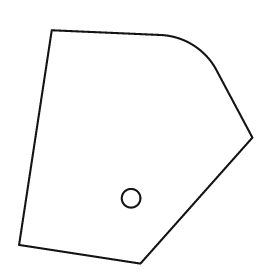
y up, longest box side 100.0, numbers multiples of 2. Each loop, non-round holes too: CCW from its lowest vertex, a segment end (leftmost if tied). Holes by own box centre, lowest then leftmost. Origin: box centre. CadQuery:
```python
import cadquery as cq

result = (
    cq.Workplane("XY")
    .moveTo(2.0, -50.0)
    .lineTo(50.0, 4.0)
    .lineTo(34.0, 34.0)
    .threePointArc((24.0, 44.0), (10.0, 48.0))
    .lineTo(-36.0, 50.0)
    .lineTo(-50.0, -42.0)
    .close()
    .moveTo(-2.0, -22.0)
    .circle(4.0)
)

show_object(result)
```